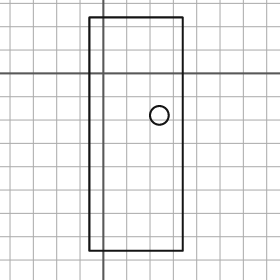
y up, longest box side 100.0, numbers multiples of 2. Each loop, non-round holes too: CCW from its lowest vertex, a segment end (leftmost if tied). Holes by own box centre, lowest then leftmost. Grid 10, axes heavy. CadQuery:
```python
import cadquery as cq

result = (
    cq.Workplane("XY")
    .moveTo(-6.0, -76.0)
    .lineTo(34.0, -76.0)
    .lineTo(34.0, 24.0)
    .lineTo(-6.0, 24.0)
    .close()
    .moveTo(24.0, -18.0)
    .circle(4.0)
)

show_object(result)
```